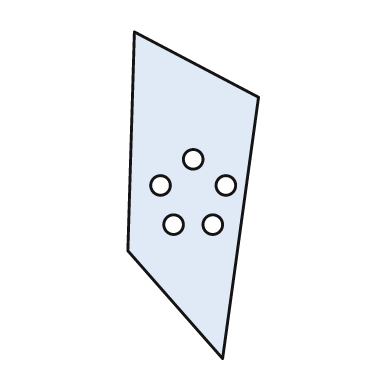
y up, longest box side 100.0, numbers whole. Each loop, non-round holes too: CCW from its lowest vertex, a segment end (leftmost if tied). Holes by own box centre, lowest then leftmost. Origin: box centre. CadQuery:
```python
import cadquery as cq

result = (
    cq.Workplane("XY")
    .moveTo(9.0, -50.0)
    .lineTo(20.0, 30.0)
    .lineTo(-18.0, 50.0)
    .lineTo(-20.0, -17.0)
    .close()
    .moveTo(-6.0, -9.0)
    .circle(3.0)
    .moveTo(6.0, -9.0)
    .circle(3.0)
    .moveTo(-10.0, 3.0)
    .circle(3.0)
    .moveTo(10.0, 3.0)
    .circle(3.0)
    .moveTo(0.0, 11.0)
    .circle(3.0)
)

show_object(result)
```